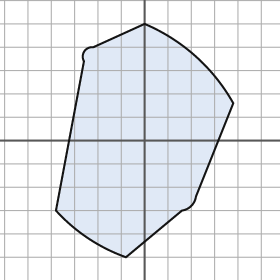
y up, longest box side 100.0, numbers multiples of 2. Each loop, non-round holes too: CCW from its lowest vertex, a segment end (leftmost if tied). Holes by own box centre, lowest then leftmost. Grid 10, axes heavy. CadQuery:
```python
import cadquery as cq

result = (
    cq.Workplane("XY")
    .moveTo(-8.0, -50.0)
    .lineTo(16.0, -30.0)
    .threePointArc((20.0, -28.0), (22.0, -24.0))
    .lineTo(38.0, 16.0)
    .threePointArc((22.0, 36.0), (0.0, 50.0))
    .lineTo(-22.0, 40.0)
    .threePointArc((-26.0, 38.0), (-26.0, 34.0))
    .lineTo(-38.0, -30.0)
    .threePointArc((-24.0, -42.0), (-8.0, -50.0))
    .close()
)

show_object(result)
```